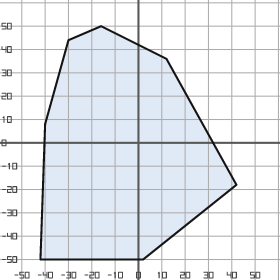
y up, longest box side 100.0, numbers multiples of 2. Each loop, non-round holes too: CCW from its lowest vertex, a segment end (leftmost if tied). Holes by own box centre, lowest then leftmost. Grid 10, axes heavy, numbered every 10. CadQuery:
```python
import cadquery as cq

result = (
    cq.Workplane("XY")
    .moveTo(-42.0, -50.0)
    .lineTo(2.0, -50.0)
    .lineTo(42.0, -18.0)
    .lineTo(12.0, 36.0)
    .lineTo(-16.0, 50.0)
    .lineTo(-30.0, 44.0)
    .lineTo(-40.0, 8.0)
    .close()
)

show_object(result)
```